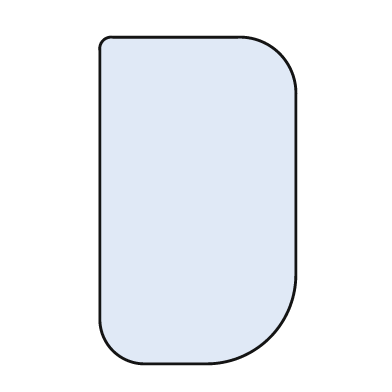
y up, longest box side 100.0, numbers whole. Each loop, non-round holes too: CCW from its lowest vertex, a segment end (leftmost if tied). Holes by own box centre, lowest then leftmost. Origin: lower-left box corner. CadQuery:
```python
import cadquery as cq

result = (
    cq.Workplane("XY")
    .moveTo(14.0, 0.0)
    .lineTo(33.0, 0.0)
    .threePointArc((52.0, 8.0), (60.0, 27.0))
    .lineTo(60.0, 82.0)
    .threePointArc((55.0, 95.0), (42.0, 100.0))
    .lineTo(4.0, 100.0)
    .threePointArc((1.0, 99.0), (0.0, 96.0))
    .lineTo(0.0, 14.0)
    .threePointArc((4.0, 4.0), (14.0, 0.0))
    .close()
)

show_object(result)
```